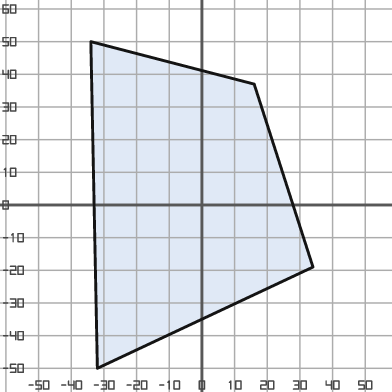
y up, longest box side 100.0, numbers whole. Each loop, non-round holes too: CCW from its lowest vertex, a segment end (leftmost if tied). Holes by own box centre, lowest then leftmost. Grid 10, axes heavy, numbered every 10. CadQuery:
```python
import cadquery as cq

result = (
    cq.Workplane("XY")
    .moveTo(-32.0, -50.0)
    .lineTo(34.0, -19.0)
    .lineTo(16.0, 37.0)
    .lineTo(-34.0, 50.0)
    .close()
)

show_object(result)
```